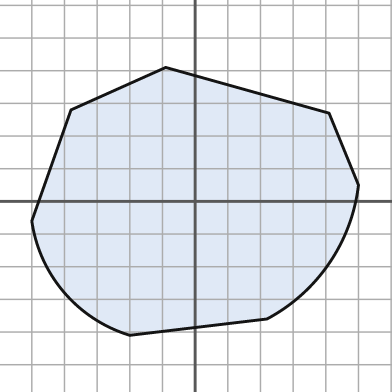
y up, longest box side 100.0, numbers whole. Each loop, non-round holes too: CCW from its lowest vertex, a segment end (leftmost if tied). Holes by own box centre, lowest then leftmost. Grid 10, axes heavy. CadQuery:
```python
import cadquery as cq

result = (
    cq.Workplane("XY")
    .moveTo(-20.0, -41.0)
    .lineTo(22.0, -36.0)
    .threePointArc((41.0, -19.0), (50.0, 5.0))
    .lineTo(41.0, 27.0)
    .lineTo(-9.0, 41.0)
    .lineTo(-38.0, 28.0)
    .lineTo(-50.0, -6.0)
    .threePointArc((-40.0, -28.0), (-20.0, -41.0))
    .close()
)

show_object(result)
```